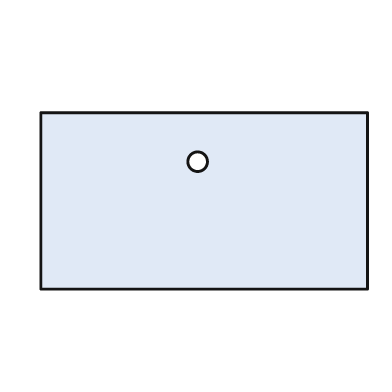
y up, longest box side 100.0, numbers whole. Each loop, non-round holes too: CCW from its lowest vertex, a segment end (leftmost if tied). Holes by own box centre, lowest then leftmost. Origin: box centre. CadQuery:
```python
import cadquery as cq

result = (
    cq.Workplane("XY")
    .moveTo(-50.0, -27.0)
    .lineTo(50.0, -27.0)
    .lineTo(50.0, 27.0)
    .lineTo(-50.0, 27.0)
    .close()
    .moveTo(-2.0, 12.0)
    .circle(3.0)
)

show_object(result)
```